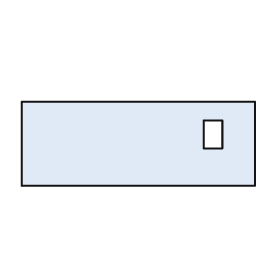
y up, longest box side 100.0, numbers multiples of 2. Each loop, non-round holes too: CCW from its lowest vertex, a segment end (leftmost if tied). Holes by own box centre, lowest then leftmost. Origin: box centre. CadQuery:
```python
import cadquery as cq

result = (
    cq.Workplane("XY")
    .moveTo(-50.0, -18.0)
    .lineTo(50.0, -18.0)
    .lineTo(50.0, 18.0)
    .lineTo(-50.0, 18.0)
    .close()
    .moveTo(28.0, -2.0)
    .lineTo(36.0, -2.0)
    .lineTo(36.0, 10.0)
    .lineTo(28.0, 10.0)
    .close()
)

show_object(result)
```